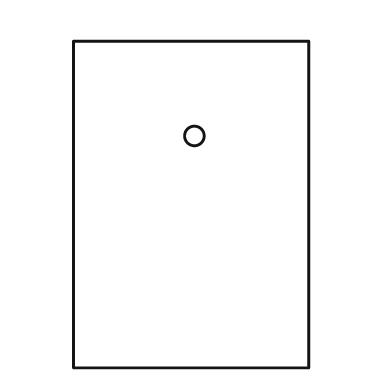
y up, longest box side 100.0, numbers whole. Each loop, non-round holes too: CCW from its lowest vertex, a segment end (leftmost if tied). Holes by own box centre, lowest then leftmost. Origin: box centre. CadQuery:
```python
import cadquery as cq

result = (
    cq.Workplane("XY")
    .moveTo(-36.0, -50.0)
    .lineTo(36.0, -50.0)
    .lineTo(36.0, 50.0)
    .lineTo(-36.0, 50.0)
    .close()
    .moveTo(1.0, 21.0)
    .circle(3.0)
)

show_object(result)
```